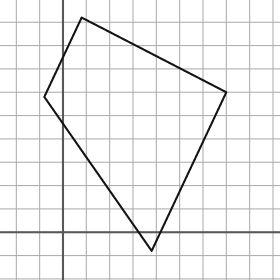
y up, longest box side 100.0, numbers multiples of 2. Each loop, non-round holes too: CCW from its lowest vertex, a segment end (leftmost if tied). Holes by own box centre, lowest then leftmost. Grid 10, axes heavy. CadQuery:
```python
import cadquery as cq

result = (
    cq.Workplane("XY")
    .moveTo(38.0, -8.0)
    .lineTo(70.0, 60.0)
    .lineTo(8.0, 92.0)
    .lineTo(-8.0, 58.0)
    .close()
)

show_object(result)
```